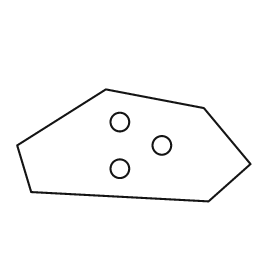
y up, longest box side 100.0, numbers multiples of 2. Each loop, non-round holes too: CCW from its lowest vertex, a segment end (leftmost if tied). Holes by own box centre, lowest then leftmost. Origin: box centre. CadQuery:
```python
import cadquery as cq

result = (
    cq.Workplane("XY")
    .moveTo(32.0, -24.0)
    .lineTo(50.0, -8.0)
    .lineTo(30.0, 16.0)
    .lineTo(-12.0, 24.0)
    .lineTo(-50.0, 0.0)
    .lineTo(-44.0, -20.0)
    .close()
    .moveTo(-6.0, -10.0)
    .circle(4.0)
    .moveTo(12.0, 0.0)
    .circle(4.0)
    .moveTo(-6.0, 10.0)
    .circle(4.0)
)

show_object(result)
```